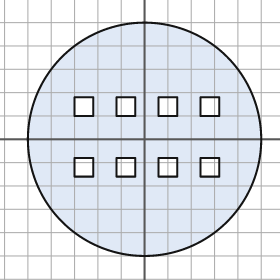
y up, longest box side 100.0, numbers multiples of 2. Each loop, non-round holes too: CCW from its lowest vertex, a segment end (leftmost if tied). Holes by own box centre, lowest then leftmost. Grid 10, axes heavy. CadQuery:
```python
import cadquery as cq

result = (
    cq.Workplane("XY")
    .moveTo(0.0, 0.0)
    .circle(50.0)
    .moveTo(-30.0, -16.0)
    .lineTo(-22.0, -16.0)
    .lineTo(-22.0, -8.0)
    .lineTo(-30.0, -8.0)
    .close()
    .moveTo(-12.0, -16.0)
    .lineTo(-4.0, -16.0)
    .lineTo(-4.0, -8.0)
    .lineTo(-12.0, -8.0)
    .close()
    .moveTo(6.0, -16.0)
    .lineTo(14.0, -16.0)
    .lineTo(14.0, -8.0)
    .lineTo(6.0, -8.0)
    .close()
    .moveTo(24.0, -16.0)
    .lineTo(32.0, -16.0)
    .lineTo(32.0, -8.0)
    .lineTo(24.0, -8.0)
    .close()
    .moveTo(-30.0, 10.0)
    .lineTo(-22.0, 10.0)
    .lineTo(-22.0, 18.0)
    .lineTo(-30.0, 18.0)
    .close()
    .moveTo(-12.0, 10.0)
    .lineTo(-4.0, 10.0)
    .lineTo(-4.0, 18.0)
    .lineTo(-12.0, 18.0)
    .close()
    .moveTo(6.0, 10.0)
    .lineTo(14.0, 10.0)
    .lineTo(14.0, 18.0)
    .lineTo(6.0, 18.0)
    .close()
    .moveTo(24.0, 10.0)
    .lineTo(32.0, 10.0)
    .lineTo(32.0, 18.0)
    .lineTo(24.0, 18.0)
    .close()
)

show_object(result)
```